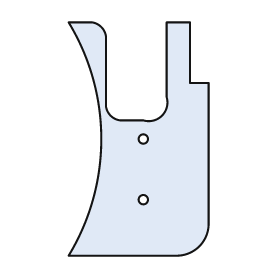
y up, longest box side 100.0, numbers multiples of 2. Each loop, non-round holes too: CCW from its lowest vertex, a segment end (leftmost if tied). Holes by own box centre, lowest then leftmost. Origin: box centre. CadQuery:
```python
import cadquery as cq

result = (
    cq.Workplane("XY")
    .moveTo(-30.0, -50.0)
    .lineTo(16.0, -50.0)
    .threePointArc((26.0, -46.0), (30.0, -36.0))
    .lineTo(30.0, 24.0)
    .lineTo(22.0, 24.0)
    .lineTo(22.0, 50.0)
    .lineTo(12.0, 50.0)
    .lineTo(12.0, 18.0)
    .threePointArc((10.0, 10.0), (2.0, 8.0))
    .lineTo(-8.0, 8.0)
    .threePointArc((-12.0, 10.0), (-14.0, 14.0))
    .lineTo(-14.0, 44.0)
    .threePointArc((-16.0, 48.0), (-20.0, 50.0))
    .lineTo(-30.0, 50.0)
    .threePointArc((-16.0, 0.0), (-30.0, -50.0))
    .close()
    .moveTo(2.0, -26.0)
    .circle(2.0)
    .moveTo(2.0, 0.0)
    .circle(2.0)
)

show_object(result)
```